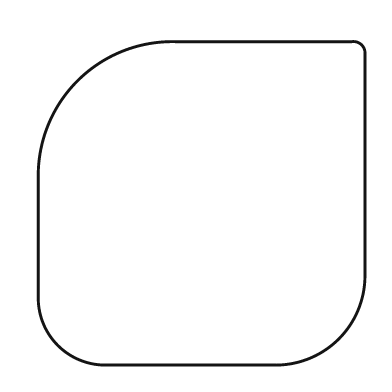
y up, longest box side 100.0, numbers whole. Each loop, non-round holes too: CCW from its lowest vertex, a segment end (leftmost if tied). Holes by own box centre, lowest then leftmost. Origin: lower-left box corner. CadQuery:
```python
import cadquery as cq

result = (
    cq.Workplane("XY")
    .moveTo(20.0, 0.0)
    .lineTo(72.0, 0.0)
    .threePointArc((92.0, 8.0), (100.0, 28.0))
    .lineTo(100.0, 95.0)
    .threePointArc((99.0, 98.0), (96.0, 99.0))
    .lineTo(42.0, 99.0)
    .threePointArc((12.0, 87.0), (0.0, 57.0))
    .lineTo(0.0, 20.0)
    .threePointArc((6.0, 6.0), (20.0, 0.0))
    .close()
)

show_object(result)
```